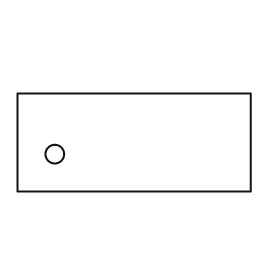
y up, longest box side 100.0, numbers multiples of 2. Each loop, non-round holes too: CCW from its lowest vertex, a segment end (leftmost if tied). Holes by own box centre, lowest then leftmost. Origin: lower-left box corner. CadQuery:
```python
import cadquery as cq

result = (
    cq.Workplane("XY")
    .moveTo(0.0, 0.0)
    .lineTo(100.0, 0.0)
    .lineTo(100.0, 42.0)
    .lineTo(0.0, 42.0)
    .close()
    .moveTo(16.0, 16.0)
    .circle(4.0)
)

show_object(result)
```